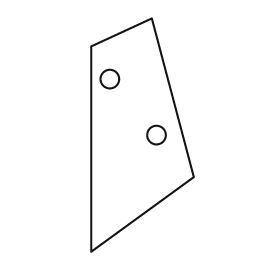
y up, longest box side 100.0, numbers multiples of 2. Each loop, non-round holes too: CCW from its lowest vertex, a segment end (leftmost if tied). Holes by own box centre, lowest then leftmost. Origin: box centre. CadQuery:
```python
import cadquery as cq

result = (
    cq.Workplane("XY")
    .moveTo(-22.0, -50.0)
    .lineTo(22.0, -18.0)
    .lineTo(4.0, 50.0)
    .lineTo(-22.0, 38.0)
    .close()
    .moveTo(6.0, 0.0)
    .circle(4.0)
    .moveTo(-14.0, 24.0)
    .circle(4.0)
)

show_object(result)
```